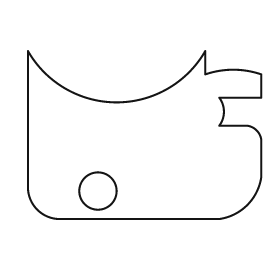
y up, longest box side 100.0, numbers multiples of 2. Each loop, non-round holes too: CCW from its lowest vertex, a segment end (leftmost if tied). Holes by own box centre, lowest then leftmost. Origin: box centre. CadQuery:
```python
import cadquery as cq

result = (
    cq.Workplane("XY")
    .moveTo(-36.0, -36.0)
    .lineTo(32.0, -36.0)
    .threePointArc((44.0, -30.0), (50.0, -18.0))
    .lineTo(50.0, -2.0)
    .threePointArc((48.0, 2.0), (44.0, 4.0))
    .lineTo(32.0, 4.0)
    .threePointArc((34.0, 10.0), (32.0, 16.0))
    .lineTo(50.0, 16.0)
    .lineTo(50.0, 26.0)
    .threePointArc((38.0, 28.0), (26.0, 26.0))
    .lineTo(26.0, 36.0)
    .threePointArc((-12.0, 14.0), (-50.0, 36.0))
    .lineTo(-50.0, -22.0)
    .threePointArc((-46.0, -32.0), (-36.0, -36.0))
    .close()
    .moveTo(-20.0, -24.0)
    .circle(8.0)
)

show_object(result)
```